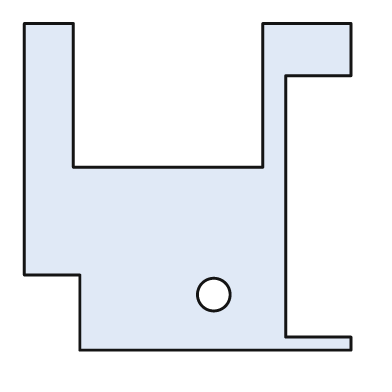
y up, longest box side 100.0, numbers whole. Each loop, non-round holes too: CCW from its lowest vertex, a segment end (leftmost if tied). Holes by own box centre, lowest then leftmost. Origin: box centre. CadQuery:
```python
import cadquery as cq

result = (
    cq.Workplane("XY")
    .moveTo(-33.0, -50.0)
    .lineTo(50.0, -50.0)
    .lineTo(50.0, -46.0)
    .lineTo(30.0, -46.0)
    .lineTo(30.0, 34.0)
    .lineTo(50.0, 34.0)
    .lineTo(50.0, 50.0)
    .lineTo(23.0, 50.0)
    .lineTo(23.0, 6.0)
    .lineTo(-35.0, 6.0)
    .lineTo(-35.0, 50.0)
    .lineTo(-50.0, 50.0)
    .lineTo(-50.0, -27.0)
    .lineTo(-33.0, -27.0)
    .close()
    .moveTo(8.0, -33.0)
    .circle(5.0)
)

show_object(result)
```